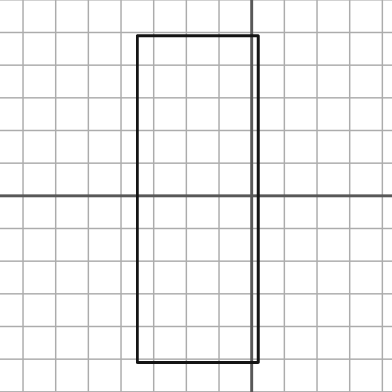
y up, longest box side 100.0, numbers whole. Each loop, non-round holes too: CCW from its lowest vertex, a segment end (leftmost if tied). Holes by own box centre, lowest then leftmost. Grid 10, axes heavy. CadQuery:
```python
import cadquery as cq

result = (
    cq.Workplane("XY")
    .moveTo(-35.0, -51.0)
    .lineTo(2.0, -51.0)
    .lineTo(2.0, 49.0)
    .lineTo(-35.0, 49.0)
    .close()
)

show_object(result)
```